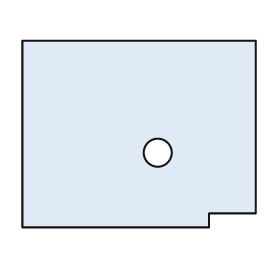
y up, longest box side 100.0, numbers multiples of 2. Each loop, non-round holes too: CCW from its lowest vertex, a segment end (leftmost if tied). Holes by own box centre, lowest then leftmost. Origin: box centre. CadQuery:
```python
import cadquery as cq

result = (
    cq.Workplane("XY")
    .moveTo(-50.0, -40.0)
    .lineTo(30.0, -40.0)
    .lineTo(30.0, -34.0)
    .lineTo(50.0, -34.0)
    .lineTo(50.0, 40.0)
    .lineTo(-50.0, 40.0)
    .close()
    .moveTo(8.0, -8.0)
    .circle(6.0)
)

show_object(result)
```